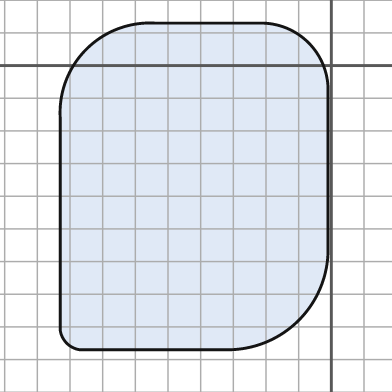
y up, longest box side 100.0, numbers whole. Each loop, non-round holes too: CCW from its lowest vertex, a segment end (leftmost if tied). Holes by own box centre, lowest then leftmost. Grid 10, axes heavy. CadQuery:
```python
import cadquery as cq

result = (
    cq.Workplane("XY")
    .moveTo(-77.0, -87.0)
    .lineTo(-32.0, -87.0)
    .threePointArc((-10.0, -78.0), (-1.0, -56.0))
    .lineTo(-1.0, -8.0)
    .threePointArc((-7.0, 7.0), (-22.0, 13.0))
    .lineTo(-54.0, 13.0)
    .threePointArc((-75.0, 5.0), (-83.0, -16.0))
    .lineTo(-83.0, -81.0)
    .threePointArc((-81.0, -85.0), (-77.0, -87.0))
    .close()
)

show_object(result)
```